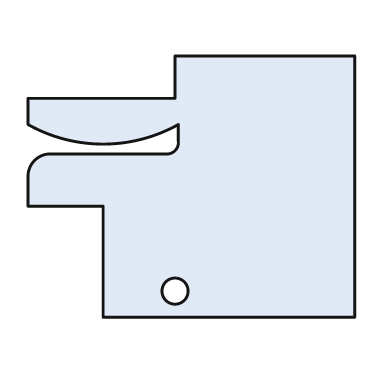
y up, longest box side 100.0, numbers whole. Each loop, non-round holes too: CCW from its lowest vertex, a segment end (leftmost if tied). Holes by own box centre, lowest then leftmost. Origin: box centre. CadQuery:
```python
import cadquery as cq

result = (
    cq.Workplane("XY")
    .moveTo(-27.0, -40.0)
    .lineTo(50.0, -40.0)
    .lineTo(50.0, 40.0)
    .lineTo(-5.0, 40.0)
    .lineTo(-5.0, 27.0)
    .lineTo(-50.0, 27.0)
    .lineTo(-50.0, 19.0)
    .threePointArc((-27.0, 13.0), (-4.0, 19.0))
    .lineTo(-4.0, 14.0)
    .threePointArc((-5.0, 11.0), (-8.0, 10.0))
    .lineTo(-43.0, 10.0)
    .threePointArc((-48.0, 8.0), (-50.0, 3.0))
    .lineTo(-50.0, -6.0)
    .lineTo(-27.0, -6.0)
    .close()
    .moveTo(-5.0, -32.0)
    .circle(4.0)
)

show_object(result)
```